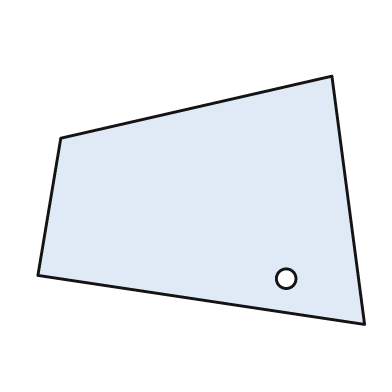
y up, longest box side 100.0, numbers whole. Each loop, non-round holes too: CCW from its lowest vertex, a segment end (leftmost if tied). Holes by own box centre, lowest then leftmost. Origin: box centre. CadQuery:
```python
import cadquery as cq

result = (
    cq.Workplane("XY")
    .moveTo(50.0, -38.0)
    .lineTo(40.0, 38.0)
    .lineTo(-43.0, 19.0)
    .lineTo(-50.0, -23.0)
    .close()
    .moveTo(26.0, -24.0)
    .circle(3.0)
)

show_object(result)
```